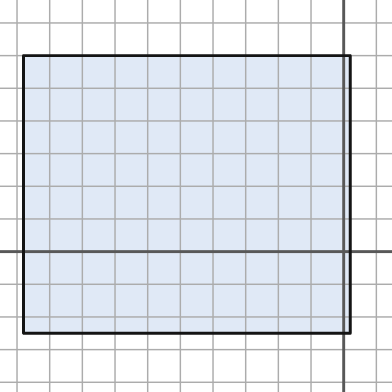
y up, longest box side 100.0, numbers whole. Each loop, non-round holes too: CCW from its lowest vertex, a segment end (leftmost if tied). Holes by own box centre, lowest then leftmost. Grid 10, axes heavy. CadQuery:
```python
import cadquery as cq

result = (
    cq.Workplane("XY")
    .moveTo(-98.0, -25.0)
    .lineTo(2.0, -25.0)
    .lineTo(2.0, 60.0)
    .lineTo(-98.0, 60.0)
    .close()
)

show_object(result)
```